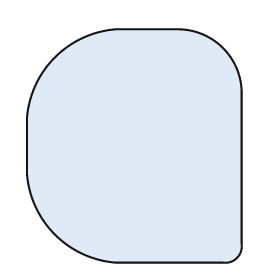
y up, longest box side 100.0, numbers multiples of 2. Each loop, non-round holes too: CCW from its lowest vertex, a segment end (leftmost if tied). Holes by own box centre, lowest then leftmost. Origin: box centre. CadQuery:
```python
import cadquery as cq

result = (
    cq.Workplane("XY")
    .moveTo(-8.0, -50.0)
    .lineTo(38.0, -50.0)
    .threePointArc((44.0, -48.0), (46.0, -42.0))
    .lineTo(46.0, 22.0)
    .threePointArc((38.0, 42.0), (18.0, 50.0))
    .lineTo(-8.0, 50.0)
    .threePointArc((-34.0, 38.0), (-46.0, 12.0))
    .lineTo(-46.0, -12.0)
    .threePointArc((-34.0, -38.0), (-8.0, -50.0))
    .close()
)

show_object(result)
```